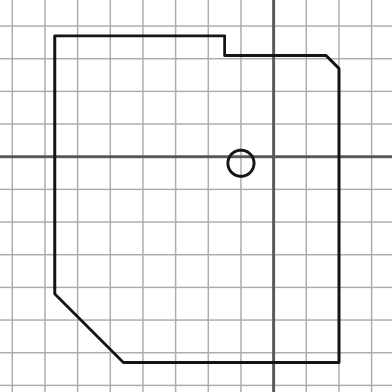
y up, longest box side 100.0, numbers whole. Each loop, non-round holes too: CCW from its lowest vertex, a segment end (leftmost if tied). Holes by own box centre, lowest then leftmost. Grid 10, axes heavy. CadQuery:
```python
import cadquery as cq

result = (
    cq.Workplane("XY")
    .moveTo(-46.0, -63.0)
    .lineTo(20.0, -63.0)
    .lineTo(20.0, 27.0)
    .lineTo(16.0, 31.0)
    .lineTo(-15.0, 31.0)
    .lineTo(-15.0, 37.0)
    .lineTo(-67.0, 37.0)
    .lineTo(-67.0, -42.0)
    .close()
    .moveTo(-10.0, -2.0)
    .circle(4.0)
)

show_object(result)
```